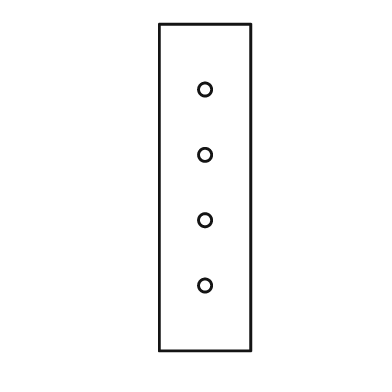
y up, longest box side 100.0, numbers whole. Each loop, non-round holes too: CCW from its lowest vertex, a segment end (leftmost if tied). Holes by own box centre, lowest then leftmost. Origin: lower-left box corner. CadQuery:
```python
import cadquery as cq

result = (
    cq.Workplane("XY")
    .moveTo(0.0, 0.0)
    .lineTo(28.0, 0.0)
    .lineTo(28.0, 100.0)
    .lineTo(0.0, 100.0)
    .close()
    .moveTo(14.0, 20.0)
    .circle(2.0)
    .moveTo(14.0, 40.0)
    .circle(2.0)
    .moveTo(14.0, 60.0)
    .circle(2.0)
    .moveTo(14.0, 80.0)
    .circle(2.0)
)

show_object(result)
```